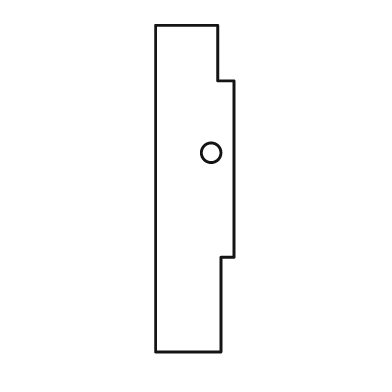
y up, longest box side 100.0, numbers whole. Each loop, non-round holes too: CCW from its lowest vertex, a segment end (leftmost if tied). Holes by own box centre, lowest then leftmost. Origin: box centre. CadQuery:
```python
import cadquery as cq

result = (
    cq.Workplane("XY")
    .moveTo(-12.0, -50.0)
    .lineTo(8.0, -50.0)
    .lineTo(8.0, -21.0)
    .lineTo(12.0, -21.0)
    .lineTo(12.0, 33.0)
    .lineTo(7.0, 33.0)
    .lineTo(7.0, 50.0)
    .lineTo(-12.0, 50.0)
    .close()
    .moveTo(5.0, 11.0)
    .circle(3.0)
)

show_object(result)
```